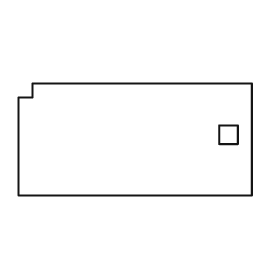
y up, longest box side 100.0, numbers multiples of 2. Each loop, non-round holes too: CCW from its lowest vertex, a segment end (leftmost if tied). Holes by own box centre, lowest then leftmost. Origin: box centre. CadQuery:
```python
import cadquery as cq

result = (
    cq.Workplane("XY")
    .moveTo(-50.0, -24.0)
    .lineTo(50.0, -24.0)
    .lineTo(50.0, 24.0)
    .lineTo(-44.0, 24.0)
    .lineTo(-44.0, 18.0)
    .lineTo(-50.0, 18.0)
    .close()
    .moveTo(36.0, -2.0)
    .lineTo(44.0, -2.0)
    .lineTo(44.0, 6.0)
    .lineTo(36.0, 6.0)
    .close()
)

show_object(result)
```